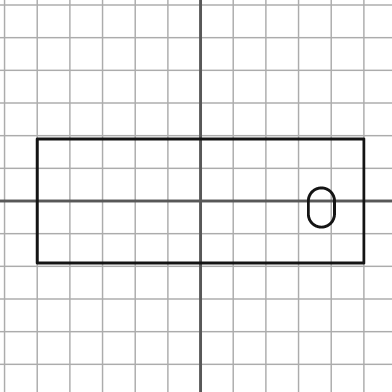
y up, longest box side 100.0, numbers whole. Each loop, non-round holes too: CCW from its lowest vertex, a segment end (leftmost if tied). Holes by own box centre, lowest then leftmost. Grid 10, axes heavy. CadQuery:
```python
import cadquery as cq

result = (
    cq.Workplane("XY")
    .moveTo(-50.0, -19.0)
    .lineTo(50.0, -19.0)
    .lineTo(50.0, 19.0)
    .lineTo(-50.0, 19.0)
    .close()
    .moveTo(33.0, -4.0)
    .threePointArc((37.0, -8.0), (41.0, -4.0))
    .lineTo(41.0, 0.0)
    .threePointArc((37.0, 4.0), (33.0, 0.0))
    .close()
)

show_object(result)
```